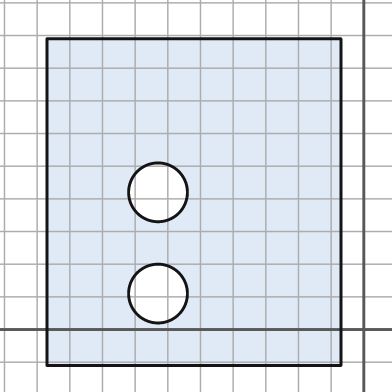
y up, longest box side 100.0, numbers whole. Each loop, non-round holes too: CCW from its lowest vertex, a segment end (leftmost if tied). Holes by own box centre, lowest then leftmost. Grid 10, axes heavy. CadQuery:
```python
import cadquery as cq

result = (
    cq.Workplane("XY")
    .moveTo(-97.0, -11.0)
    .lineTo(-7.0, -11.0)
    .lineTo(-7.0, 89.0)
    .lineTo(-97.0, 89.0)
    .close()
    .moveTo(-63.0, 11.0)
    .circle(9.0)
    .moveTo(-63.0, 42.0)
    .circle(9.0)
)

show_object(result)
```